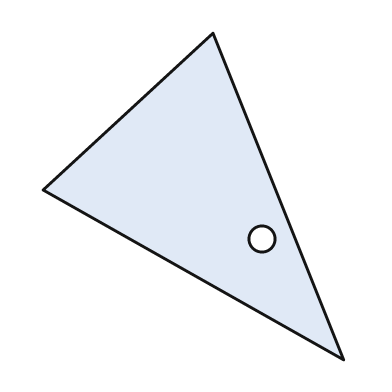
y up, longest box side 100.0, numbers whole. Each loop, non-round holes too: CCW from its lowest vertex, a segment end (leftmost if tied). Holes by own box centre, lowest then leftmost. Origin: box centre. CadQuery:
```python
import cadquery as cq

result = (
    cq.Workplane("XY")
    .moveTo(46.0, -50.0)
    .lineTo(6.0, 50.0)
    .lineTo(-46.0, 2.0)
    .close()
    .moveTo(21.0, -13.0)
    .circle(4.0)
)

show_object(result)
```